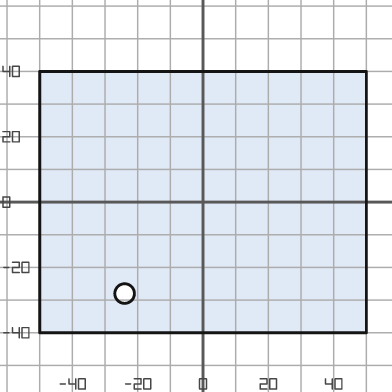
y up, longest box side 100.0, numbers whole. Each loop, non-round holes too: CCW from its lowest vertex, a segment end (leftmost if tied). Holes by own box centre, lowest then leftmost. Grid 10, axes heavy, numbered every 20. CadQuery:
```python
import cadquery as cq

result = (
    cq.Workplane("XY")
    .moveTo(-50.0, -40.0)
    .lineTo(50.0, -40.0)
    .lineTo(50.0, 40.0)
    .lineTo(-50.0, 40.0)
    .close()
    .moveTo(-24.0, -28.0)
    .circle(3.0)
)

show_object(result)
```